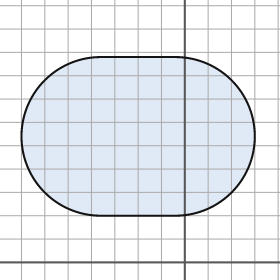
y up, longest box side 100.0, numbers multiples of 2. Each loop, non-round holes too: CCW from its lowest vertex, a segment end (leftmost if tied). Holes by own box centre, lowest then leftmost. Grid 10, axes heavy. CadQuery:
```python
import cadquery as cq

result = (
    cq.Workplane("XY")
    .moveTo(-36.0, 20.0)
    .lineTo(-4.0, 20.0)
    .threePointArc((30.0, 54.0), (-4.0, 88.0))
    .lineTo(-36.0, 88.0)
    .threePointArc((-70.0, 54.0), (-36.0, 20.0))
    .close()
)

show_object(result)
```